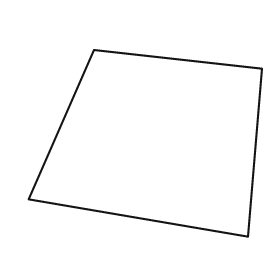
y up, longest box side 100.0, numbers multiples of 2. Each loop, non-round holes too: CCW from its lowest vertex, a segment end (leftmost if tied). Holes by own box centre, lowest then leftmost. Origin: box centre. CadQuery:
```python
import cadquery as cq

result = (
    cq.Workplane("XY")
    .moveTo(44.0, -40.0)
    .lineTo(50.0, 32.0)
    .lineTo(-22.0, 40.0)
    .lineTo(-50.0, -24.0)
    .close()
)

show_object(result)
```